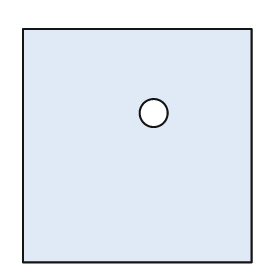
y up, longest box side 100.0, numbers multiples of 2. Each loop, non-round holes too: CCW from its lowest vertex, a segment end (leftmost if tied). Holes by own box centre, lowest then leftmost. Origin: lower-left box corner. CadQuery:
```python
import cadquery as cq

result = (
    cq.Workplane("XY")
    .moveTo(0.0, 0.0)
    .lineTo(98.0, 0.0)
    .lineTo(98.0, 100.0)
    .lineTo(0.0, 100.0)
    .close()
    .moveTo(56.0, 64.0)
    .circle(6.0)
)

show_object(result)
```